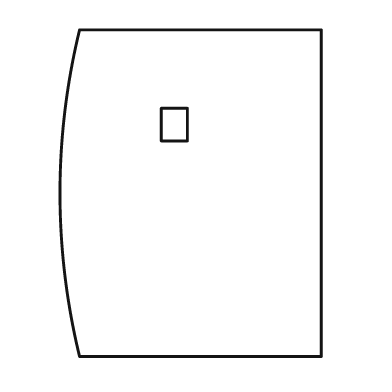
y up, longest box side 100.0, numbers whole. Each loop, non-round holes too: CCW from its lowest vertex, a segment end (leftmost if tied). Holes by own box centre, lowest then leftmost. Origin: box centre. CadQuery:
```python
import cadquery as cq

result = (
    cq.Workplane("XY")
    .moveTo(-34.0, -50.0)
    .lineTo(40.0, -50.0)
    .lineTo(40.0, 50.0)
    .lineTo(-34.0, 50.0)
    .threePointArc((-40.0, 0.0), (-34.0, -50.0))
    .close()
    .moveTo(-9.0, 16.0)
    .lineTo(-1.0, 16.0)
    .lineTo(-1.0, 26.0)
    .lineTo(-9.0, 26.0)
    .close()
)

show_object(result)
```